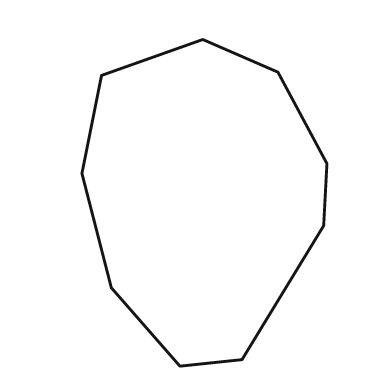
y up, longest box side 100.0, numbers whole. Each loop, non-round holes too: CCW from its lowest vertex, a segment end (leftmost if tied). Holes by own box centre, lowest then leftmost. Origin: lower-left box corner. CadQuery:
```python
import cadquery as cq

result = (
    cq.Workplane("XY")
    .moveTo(30.0, 0.0)
    .lineTo(49.0, 2.0)
    .lineTo(74.0, 43.0)
    .lineTo(75.0, 62.0)
    .lineTo(60.0, 90.0)
    .lineTo(37.0, 100.0)
    .lineTo(6.0, 89.0)
    .lineTo(0.0, 59.0)
    .lineTo(9.0, 24.0)
    .close()
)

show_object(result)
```